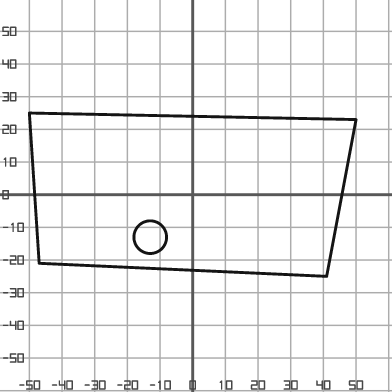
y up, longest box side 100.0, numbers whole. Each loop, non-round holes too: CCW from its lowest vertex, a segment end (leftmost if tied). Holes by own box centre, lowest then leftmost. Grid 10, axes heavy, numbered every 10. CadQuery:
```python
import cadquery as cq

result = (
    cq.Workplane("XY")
    .moveTo(41.0, -25.0)
    .lineTo(50.0, 23.0)
    .lineTo(-50.0, 25.0)
    .lineTo(-47.0, -21.0)
    .close()
    .moveTo(-13.0, -13.0)
    .circle(5.0)
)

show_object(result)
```